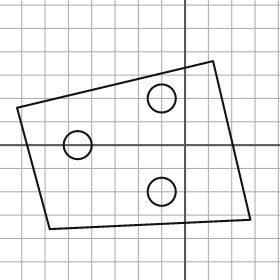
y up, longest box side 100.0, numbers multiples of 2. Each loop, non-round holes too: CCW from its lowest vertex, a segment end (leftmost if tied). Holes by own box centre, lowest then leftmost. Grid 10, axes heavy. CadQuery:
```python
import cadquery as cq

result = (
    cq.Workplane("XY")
    .moveTo(-58.0, -36.0)
    .lineTo(28.0, -32.0)
    .lineTo(12.0, 36.0)
    .lineTo(-72.0, 16.0)
    .close()
    .moveTo(-10.0, -20.0)
    .circle(6.0)
    .moveTo(-46.0, 0.0)
    .circle(6.0)
    .moveTo(-10.0, 20.0)
    .circle(6.0)
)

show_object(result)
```